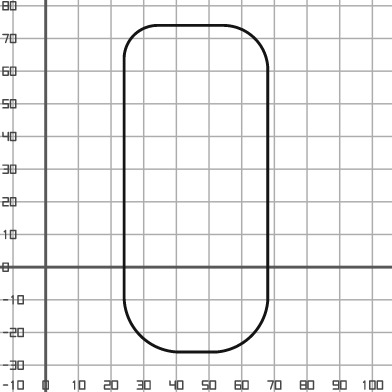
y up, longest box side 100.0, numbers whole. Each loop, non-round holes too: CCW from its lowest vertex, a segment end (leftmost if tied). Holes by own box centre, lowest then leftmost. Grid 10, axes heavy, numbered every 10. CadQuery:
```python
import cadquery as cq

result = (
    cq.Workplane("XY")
    .moveTo(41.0, -26.0)
    .lineTo(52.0, -26.0)
    .threePointArc((63.0, -21.0), (68.0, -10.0))
    .lineTo(68.0, 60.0)
    .threePointArc((64.0, 70.0), (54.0, 74.0))
    .lineTo(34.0, 74.0)
    .threePointArc((27.0, 71.0), (24.0, 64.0))
    .lineTo(24.0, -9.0)
    .threePointArc((29.0, -21.0), (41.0, -26.0))
    .close()
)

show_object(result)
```